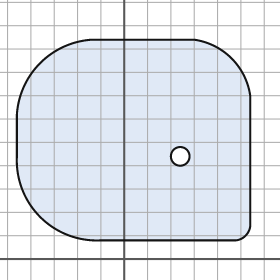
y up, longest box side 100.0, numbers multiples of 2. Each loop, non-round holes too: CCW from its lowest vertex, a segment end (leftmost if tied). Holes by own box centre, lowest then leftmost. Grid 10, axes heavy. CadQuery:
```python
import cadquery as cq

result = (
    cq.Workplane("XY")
    .moveTo(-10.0, 8.0)
    .lineTo(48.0, 8.0)
    .threePointArc((52.0, 10.0), (54.0, 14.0))
    .lineTo(54.0, 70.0)
    .threePointArc((46.0, 86.0), (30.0, 94.0))
    .lineTo(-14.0, 94.0)
    .threePointArc((-36.0, 84.0), (-46.0, 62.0))
    .lineTo(-46.0, 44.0)
    .threePointArc((-36.0, 18.0), (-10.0, 8.0))
    .close()
    .moveTo(24.0, 44.0)
    .circle(4.0)
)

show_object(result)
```